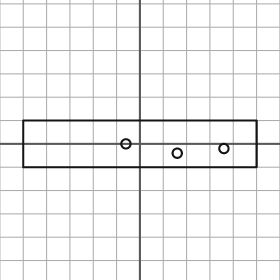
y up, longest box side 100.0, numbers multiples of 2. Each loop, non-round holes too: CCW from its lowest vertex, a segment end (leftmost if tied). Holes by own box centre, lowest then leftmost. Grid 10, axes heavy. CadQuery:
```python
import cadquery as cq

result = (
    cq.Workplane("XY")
    .moveTo(-50.0, -10.0)
    .lineTo(50.0, -10.0)
    .lineTo(50.0, 10.0)
    .lineTo(-50.0, 10.0)
    .close()
    .moveTo(16.0, -4.0)
    .circle(2.0)
    .moveTo(36.0, -2.0)
    .circle(2.0)
    .moveTo(-6.0, 0.0)
    .circle(2.0)
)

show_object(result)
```